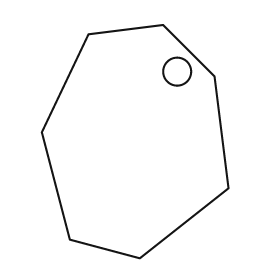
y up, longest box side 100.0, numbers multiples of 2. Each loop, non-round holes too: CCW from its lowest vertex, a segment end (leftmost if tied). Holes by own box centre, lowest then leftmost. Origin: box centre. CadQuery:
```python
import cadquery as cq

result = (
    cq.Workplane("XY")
    .moveTo(2.0, -50.0)
    .lineTo(40.0, -20.0)
    .lineTo(34.0, 28.0)
    .lineTo(12.0, 50.0)
    .lineTo(-20.0, 46.0)
    .lineTo(-40.0, 4.0)
    .lineTo(-28.0, -42.0)
    .close()
    .moveTo(18.0, 30.0)
    .circle(6.0)
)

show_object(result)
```